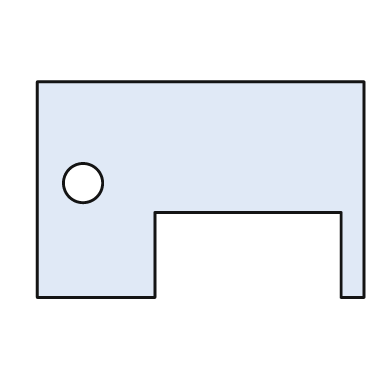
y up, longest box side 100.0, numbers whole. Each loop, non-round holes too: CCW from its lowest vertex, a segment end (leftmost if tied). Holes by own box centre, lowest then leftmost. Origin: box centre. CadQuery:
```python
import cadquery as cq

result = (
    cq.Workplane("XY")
    .moveTo(-50.0, -33.0)
    .lineTo(-14.0, -33.0)
    .lineTo(-14.0, -7.0)
    .lineTo(43.0, -7.0)
    .lineTo(43.0, -33.0)
    .lineTo(50.0, -33.0)
    .lineTo(50.0, 33.0)
    .lineTo(-50.0, 33.0)
    .close()
    .moveTo(-36.0, 2.0)
    .circle(6.0)
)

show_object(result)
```